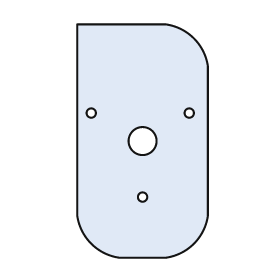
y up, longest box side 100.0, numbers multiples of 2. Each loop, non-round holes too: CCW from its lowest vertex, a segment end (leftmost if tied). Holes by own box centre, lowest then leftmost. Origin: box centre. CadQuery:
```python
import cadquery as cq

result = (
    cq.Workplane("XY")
    .moveTo(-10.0, -50.0)
    .lineTo(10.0, -50.0)
    .threePointArc((22.0, -44.0), (28.0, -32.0))
    .lineTo(28.0, 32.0)
    .threePointArc((22.0, 44.0), (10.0, 50.0))
    .lineTo(-28.0, 50.0)
    .lineTo(-28.0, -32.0)
    .threePointArc((-22.0, -44.0), (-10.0, -50.0))
    .close()
    .moveTo(0.0, -24.0)
    .circle(2.0)
    .moveTo(0.0, 0.0)
    .circle(6.0)
    .moveTo(-22.0, 12.0)
    .circle(2.0)
    .moveTo(20.0, 12.0)
    .circle(2.0)
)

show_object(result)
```